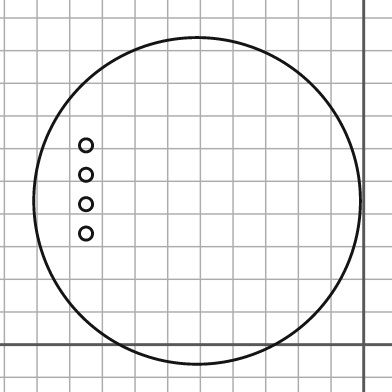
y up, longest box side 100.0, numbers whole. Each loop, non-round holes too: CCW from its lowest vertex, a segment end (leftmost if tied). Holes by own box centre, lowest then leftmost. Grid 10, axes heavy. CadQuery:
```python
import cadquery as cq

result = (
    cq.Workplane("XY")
    .moveTo(-51.0, 44.0)
    .circle(50.0)
    .moveTo(-85.0, 34.0)
    .circle(2.0)
    .moveTo(-85.0, 43.0)
    .circle(2.0)
    .moveTo(-85.0, 52.0)
    .circle(2.0)
    .moveTo(-85.0, 61.0)
    .circle(2.0)
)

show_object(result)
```